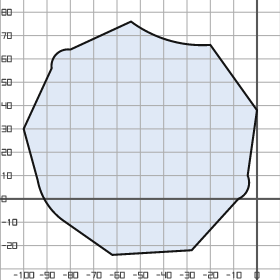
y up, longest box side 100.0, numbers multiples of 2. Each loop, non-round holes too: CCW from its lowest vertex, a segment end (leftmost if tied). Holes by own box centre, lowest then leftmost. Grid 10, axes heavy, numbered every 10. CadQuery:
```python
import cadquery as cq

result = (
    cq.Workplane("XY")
    .moveTo(-62.0, -24.0)
    .lineTo(-28.0, -22.0)
    .lineTo(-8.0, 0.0)
    .threePointArc((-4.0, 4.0), (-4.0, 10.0))
    .lineTo(0.0, 38.0)
    .lineTo(-20.0, 66.0)
    .threePointArc((-38.0, 68.0), (-54.0, 76.0))
    .lineTo(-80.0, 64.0)
    .threePointArc((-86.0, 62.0), (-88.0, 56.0))
    .lineTo(-100.0, 30.0)
    .lineTo(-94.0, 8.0)
    .threePointArc((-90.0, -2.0), (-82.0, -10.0))
    .close()
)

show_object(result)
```